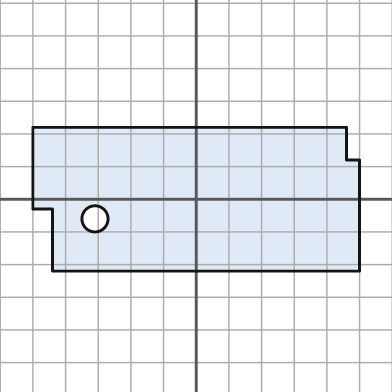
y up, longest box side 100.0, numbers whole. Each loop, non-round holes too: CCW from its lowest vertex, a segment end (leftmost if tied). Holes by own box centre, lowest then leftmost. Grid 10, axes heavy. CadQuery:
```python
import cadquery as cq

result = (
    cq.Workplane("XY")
    .moveTo(-44.0, -22.0)
    .lineTo(50.0, -22.0)
    .lineTo(50.0, 12.0)
    .lineTo(46.0, 12.0)
    .lineTo(46.0, 22.0)
    .lineTo(-50.0, 22.0)
    .lineTo(-50.0, -3.0)
    .lineTo(-44.0, -3.0)
    .close()
    .moveTo(-31.0, -6.0)
    .circle(4.0)
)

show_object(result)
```